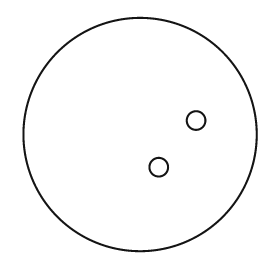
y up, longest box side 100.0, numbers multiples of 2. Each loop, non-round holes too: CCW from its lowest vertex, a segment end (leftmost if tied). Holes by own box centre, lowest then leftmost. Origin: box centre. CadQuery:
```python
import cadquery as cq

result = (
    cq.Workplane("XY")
    .moveTo(0.0, 0.0)
    .circle(50.0)
    .moveTo(8.0, -14.0)
    .circle(4.0)
    .moveTo(24.0, 6.0)
    .circle(4.0)
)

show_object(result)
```